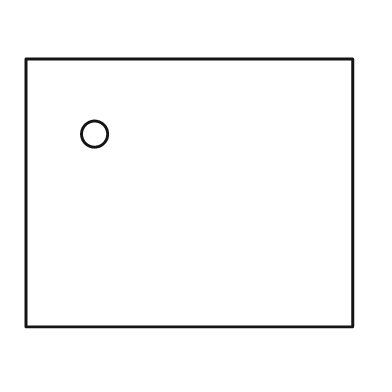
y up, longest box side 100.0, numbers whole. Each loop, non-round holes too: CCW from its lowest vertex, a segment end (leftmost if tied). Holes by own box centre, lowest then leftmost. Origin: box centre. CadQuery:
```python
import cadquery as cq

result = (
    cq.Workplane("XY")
    .moveTo(-50.0, -41.0)
    .lineTo(50.0, -41.0)
    .lineTo(50.0, 41.0)
    .lineTo(-50.0, 41.0)
    .close()
    .moveTo(-29.0, 18.0)
    .circle(4.0)
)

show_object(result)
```